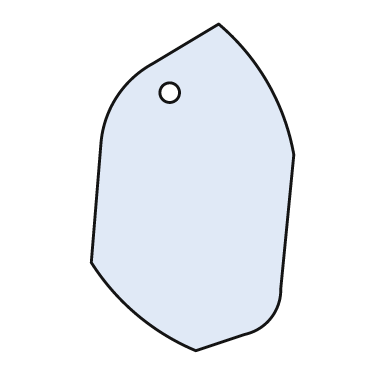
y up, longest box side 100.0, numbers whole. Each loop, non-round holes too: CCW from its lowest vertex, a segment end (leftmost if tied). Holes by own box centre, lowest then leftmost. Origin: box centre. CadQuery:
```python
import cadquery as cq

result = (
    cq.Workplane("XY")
    .moveTo(1.0, -50.0)
    .lineTo(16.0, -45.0)
    .threePointArc((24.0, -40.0), (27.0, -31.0))
    .lineTo(31.0, 10.0)
    .threePointArc((23.0, 32.0), (8.0, 50.0))
    .lineTo(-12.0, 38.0)
    .threePointArc((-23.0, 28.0), (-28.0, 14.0))
    .lineTo(-31.0, -23.0)
    .threePointArc((-17.0, -39.0), (1.0, -50.0))
    .close()
    .moveTo(-7.0, 29.0)
    .circle(3.0)
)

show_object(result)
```